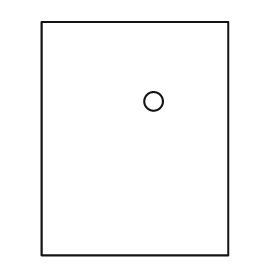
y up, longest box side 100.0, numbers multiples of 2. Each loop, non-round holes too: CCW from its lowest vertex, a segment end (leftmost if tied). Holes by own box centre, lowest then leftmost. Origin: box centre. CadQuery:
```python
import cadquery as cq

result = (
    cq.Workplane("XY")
    .moveTo(-40.0, -50.0)
    .lineTo(40.0, -50.0)
    .lineTo(40.0, 50.0)
    .lineTo(-40.0, 50.0)
    .close()
    .moveTo(8.0, 16.0)
    .circle(4.0)
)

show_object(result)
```